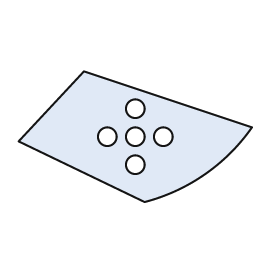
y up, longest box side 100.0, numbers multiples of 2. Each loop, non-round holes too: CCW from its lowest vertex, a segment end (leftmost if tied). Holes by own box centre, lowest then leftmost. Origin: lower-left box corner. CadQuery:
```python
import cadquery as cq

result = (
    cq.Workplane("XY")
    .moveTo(54.0, 0.0)
    .threePointArc((80.0, 12.0), (100.0, 32.0))
    .lineTo(28.0, 56.0)
    .lineTo(0.0, 26.0)
    .close()
    .moveTo(50.0, 16.0)
    .circle(4.0)
    .moveTo(38.0, 28.0)
    .circle(4.0)
    .moveTo(50.0, 28.0)
    .circle(4.0)
    .moveTo(62.0, 28.0)
    .circle(4.0)
    .moveTo(50.0, 40.0)
    .circle(4.0)
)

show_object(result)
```